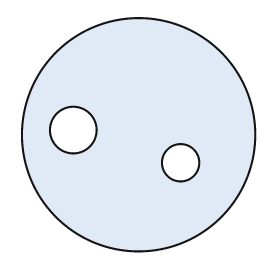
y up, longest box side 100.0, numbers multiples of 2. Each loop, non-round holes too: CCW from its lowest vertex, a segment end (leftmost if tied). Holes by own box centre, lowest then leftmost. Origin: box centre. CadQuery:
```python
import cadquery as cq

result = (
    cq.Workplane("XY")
    .moveTo(0.0, 0.0)
    .circle(50.0)
    .moveTo(18.0, -12.0)
    .circle(8.0)
    .moveTo(-28.0, 2.0)
    .circle(10.0)
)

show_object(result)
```